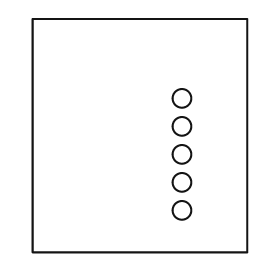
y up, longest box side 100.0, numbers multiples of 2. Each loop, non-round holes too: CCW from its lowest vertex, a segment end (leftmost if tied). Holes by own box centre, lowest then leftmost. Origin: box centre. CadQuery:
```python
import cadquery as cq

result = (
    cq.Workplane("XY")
    .moveTo(-46.0, -50.0)
    .lineTo(46.0, -50.0)
    .lineTo(46.0, 50.0)
    .lineTo(-46.0, 50.0)
    .close()
    .moveTo(18.0, -32.0)
    .circle(4.0)
    .moveTo(18.0, -20.0)
    .circle(4.0)
    .moveTo(18.0, -8.0)
    .circle(4.0)
    .moveTo(18.0, 4.0)
    .circle(4.0)
    .moveTo(18.0, 16.0)
    .circle(4.0)
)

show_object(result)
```